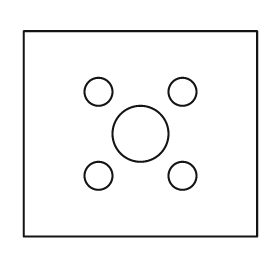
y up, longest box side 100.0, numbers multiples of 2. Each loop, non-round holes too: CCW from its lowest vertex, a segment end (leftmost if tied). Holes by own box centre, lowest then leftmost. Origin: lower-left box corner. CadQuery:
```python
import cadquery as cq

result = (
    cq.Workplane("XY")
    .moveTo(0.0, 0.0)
    .lineTo(100.0, 0.0)
    .lineTo(100.0, 88.0)
    .lineTo(0.0, 88.0)
    .close()
    .moveTo(32.0, 26.0)
    .circle(6.0)
    .moveTo(68.0, 26.0)
    .circle(6.0)
    .moveTo(50.0, 44.0)
    .circle(12.0)
    .moveTo(32.0, 62.0)
    .circle(6.0)
    .moveTo(68.0, 62.0)
    .circle(6.0)
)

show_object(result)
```